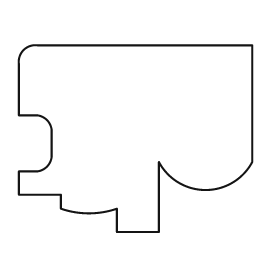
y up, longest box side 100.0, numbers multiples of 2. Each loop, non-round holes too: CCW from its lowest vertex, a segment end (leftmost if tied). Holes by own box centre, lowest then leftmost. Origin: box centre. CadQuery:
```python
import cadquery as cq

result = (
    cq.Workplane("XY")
    .moveTo(-8.0, -40.0)
    .lineTo(10.0, -40.0)
    .lineTo(10.0, -10.0)
    .threePointArc((30.0, -22.0), (50.0, -10.0))
    .lineTo(50.0, 40.0)
    .lineTo(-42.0, 40.0)
    .threePointArc((-48.0, 38.0), (-50.0, 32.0))
    .lineTo(-50.0, 10.0)
    .lineTo(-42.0, 10.0)
    .threePointArc((-38.0, 8.0), (-36.0, 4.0))
    .lineTo(-36.0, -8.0)
    .threePointArc((-38.0, -12.0), (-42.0, -14.0))
    .lineTo(-50.0, -14.0)
    .lineTo(-50.0, -24.0)
    .lineTo(-32.0, -24.0)
    .lineTo(-32.0, -30.0)
    .threePointArc((-20.0, -32.0), (-8.0, -30.0))
    .close()
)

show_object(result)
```